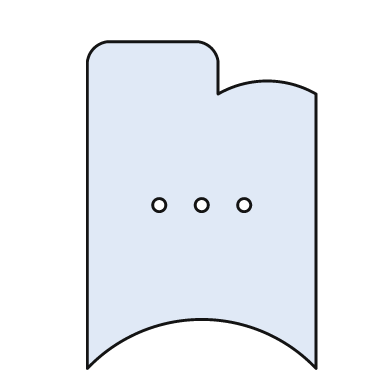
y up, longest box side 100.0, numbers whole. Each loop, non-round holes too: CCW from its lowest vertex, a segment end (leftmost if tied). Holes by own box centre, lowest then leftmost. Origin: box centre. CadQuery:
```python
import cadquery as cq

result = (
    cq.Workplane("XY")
    .moveTo(-35.0, -50.0)
    .threePointArc((0.0, -35.0), (35.0, -50.0))
    .lineTo(35.0, 34.0)
    .threePointArc((20.0, 38.0), (5.0, 34.0))
    .lineTo(5.0, 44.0)
    .threePointArc((3.0, 48.0), (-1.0, 50.0))
    .lineTo(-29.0, 50.0)
    .threePointArc((-33.0, 48.0), (-35.0, 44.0))
    .close()
    .moveTo(-13.0, 0.0)
    .circle(2.0)
    .moveTo(0.0, 0.0)
    .circle(2.0)
    .moveTo(13.0, 0.0)
    .circle(2.0)
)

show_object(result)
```